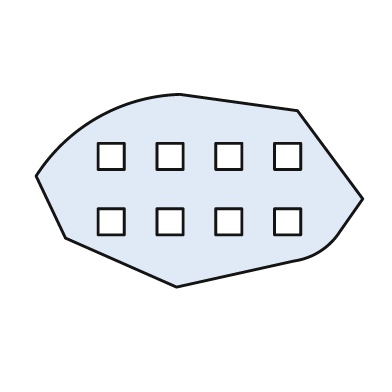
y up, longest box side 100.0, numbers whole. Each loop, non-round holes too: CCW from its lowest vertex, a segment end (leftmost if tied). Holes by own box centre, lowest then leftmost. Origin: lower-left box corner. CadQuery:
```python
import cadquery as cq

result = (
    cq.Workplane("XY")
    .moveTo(43.0, 0.0)
    .lineTo(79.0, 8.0)
    .threePointArc((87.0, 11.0), (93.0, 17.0))
    .lineTo(100.0, 27.0)
    .lineTo(80.0, 54.0)
    .lineTo(44.0, 59.0)
    .threePointArc((19.0, 52.0), (0.0, 34.0))
    .lineTo(9.0, 15.0)
    .close()
    .moveTo(19.0, 16.0)
    .lineTo(27.0, 16.0)
    .lineTo(27.0, 24.0)
    .lineTo(19.0, 24.0)
    .close()
    .moveTo(37.0, 16.0)
    .lineTo(45.0, 16.0)
    .lineTo(45.0, 24.0)
    .lineTo(37.0, 24.0)
    .close()
    .moveTo(55.0, 16.0)
    .lineTo(63.0, 16.0)
    .lineTo(63.0, 24.0)
    .lineTo(55.0, 24.0)
    .close()
    .moveTo(73.0, 16.0)
    .lineTo(81.0, 16.0)
    .lineTo(81.0, 24.0)
    .lineTo(73.0, 24.0)
    .close()
    .moveTo(19.0, 36.0)
    .lineTo(27.0, 36.0)
    .lineTo(27.0, 44.0)
    .lineTo(19.0, 44.0)
    .close()
    .moveTo(37.0, 36.0)
    .lineTo(45.0, 36.0)
    .lineTo(45.0, 44.0)
    .lineTo(37.0, 44.0)
    .close()
    .moveTo(55.0, 36.0)
    .lineTo(63.0, 36.0)
    .lineTo(63.0, 44.0)
    .lineTo(55.0, 44.0)
    .close()
    .moveTo(73.0, 36.0)
    .lineTo(81.0, 36.0)
    .lineTo(81.0, 44.0)
    .lineTo(73.0, 44.0)
    .close()
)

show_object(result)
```